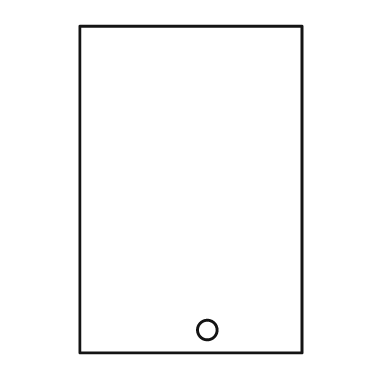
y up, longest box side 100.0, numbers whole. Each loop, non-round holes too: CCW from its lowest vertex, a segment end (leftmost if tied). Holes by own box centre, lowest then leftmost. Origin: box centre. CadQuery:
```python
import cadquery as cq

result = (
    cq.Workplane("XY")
    .moveTo(-34.0, -50.0)
    .lineTo(34.0, -50.0)
    .lineTo(34.0, 50.0)
    .lineTo(-34.0, 50.0)
    .close()
    .moveTo(5.0, -43.0)
    .circle(3.0)
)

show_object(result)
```